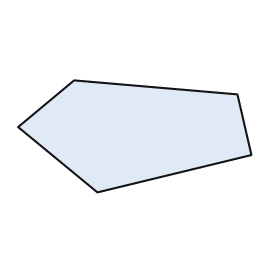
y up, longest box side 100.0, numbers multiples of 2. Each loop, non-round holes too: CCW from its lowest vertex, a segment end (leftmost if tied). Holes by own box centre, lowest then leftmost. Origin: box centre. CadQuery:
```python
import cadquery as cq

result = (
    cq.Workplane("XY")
    .moveTo(-16.0, -24.0)
    .lineTo(50.0, -8.0)
    .lineTo(44.0, 18.0)
    .lineTo(-26.0, 24.0)
    .lineTo(-50.0, 4.0)
    .close()
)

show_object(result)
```